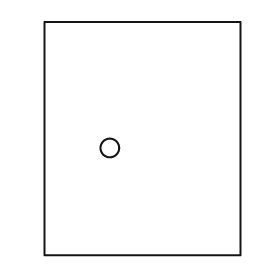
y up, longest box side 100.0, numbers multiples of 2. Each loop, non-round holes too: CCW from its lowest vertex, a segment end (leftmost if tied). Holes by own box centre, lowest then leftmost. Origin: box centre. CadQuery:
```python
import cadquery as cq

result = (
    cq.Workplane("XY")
    .moveTo(-42.0, -50.0)
    .lineTo(42.0, -50.0)
    .lineTo(42.0, 50.0)
    .lineTo(-42.0, 50.0)
    .close()
    .moveTo(-14.0, -4.0)
    .circle(4.0)
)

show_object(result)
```